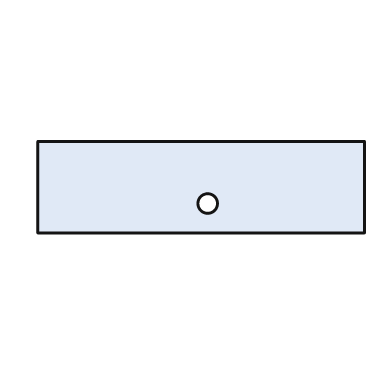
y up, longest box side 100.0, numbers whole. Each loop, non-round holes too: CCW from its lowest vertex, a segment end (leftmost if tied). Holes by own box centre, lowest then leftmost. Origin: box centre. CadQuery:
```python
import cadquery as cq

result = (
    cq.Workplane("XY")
    .moveTo(-50.0, -14.0)
    .lineTo(50.0, -14.0)
    .lineTo(50.0, 14.0)
    .lineTo(-50.0, 14.0)
    .close()
    .moveTo(2.0, -5.0)
    .circle(3.0)
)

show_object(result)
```